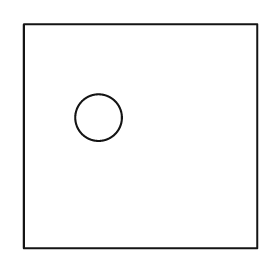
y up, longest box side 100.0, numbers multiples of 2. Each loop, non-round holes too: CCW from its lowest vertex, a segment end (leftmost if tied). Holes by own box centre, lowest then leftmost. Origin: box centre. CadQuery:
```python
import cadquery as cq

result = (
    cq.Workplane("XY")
    .moveTo(-50.0, -48.0)
    .lineTo(50.0, -48.0)
    .lineTo(50.0, 48.0)
    .lineTo(-50.0, 48.0)
    .close()
    .moveTo(-18.0, 8.0)
    .circle(10.0)
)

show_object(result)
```